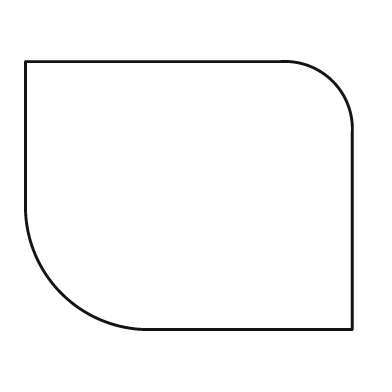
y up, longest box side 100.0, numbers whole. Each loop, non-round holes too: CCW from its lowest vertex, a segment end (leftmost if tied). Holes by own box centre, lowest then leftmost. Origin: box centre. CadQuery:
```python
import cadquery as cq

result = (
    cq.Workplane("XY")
    .moveTo(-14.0, -41.0)
    .lineTo(50.0, -41.0)
    .lineTo(50.0, 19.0)
    .threePointArc((44.0, 35.0), (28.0, 41.0))
    .lineTo(-50.0, 41.0)
    .lineTo(-50.0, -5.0)
    .threePointArc((-39.0, -30.0), (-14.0, -41.0))
    .close()
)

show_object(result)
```